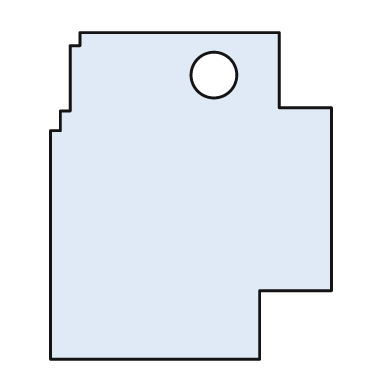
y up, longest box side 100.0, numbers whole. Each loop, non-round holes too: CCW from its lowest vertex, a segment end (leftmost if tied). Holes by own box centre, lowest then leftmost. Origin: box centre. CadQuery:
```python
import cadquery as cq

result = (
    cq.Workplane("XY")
    .moveTo(-43.0, -50.0)
    .lineTo(21.0, -50.0)
    .lineTo(21.0, -29.0)
    .lineTo(43.0, -29.0)
    .lineTo(43.0, 27.0)
    .lineTo(27.0, 27.0)
    .lineTo(27.0, 50.0)
    .lineTo(-34.0, 50.0)
    .lineTo(-34.0, 46.0)
    .lineTo(-37.0, 46.0)
    .lineTo(-37.0, 26.0)
    .lineTo(-40.0, 26.0)
    .lineTo(-40.0, 20.0)
    .lineTo(-43.0, 20.0)
    .close()
    .moveTo(7.0, 37.0)
    .circle(7.0)
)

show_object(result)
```